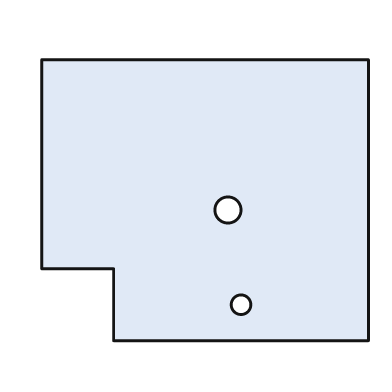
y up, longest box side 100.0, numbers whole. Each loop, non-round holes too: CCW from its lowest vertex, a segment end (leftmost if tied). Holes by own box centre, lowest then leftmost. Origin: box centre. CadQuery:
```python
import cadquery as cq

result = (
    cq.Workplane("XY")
    .moveTo(-28.0, -43.0)
    .lineTo(50.0, -43.0)
    .lineTo(50.0, 43.0)
    .lineTo(-50.0, 43.0)
    .lineTo(-50.0, -21.0)
    .lineTo(-28.0, -21.0)
    .close()
    .moveTo(11.0, -32.0)
    .circle(3.0)
    .moveTo(7.0, -3.0)
    .circle(4.0)
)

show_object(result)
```